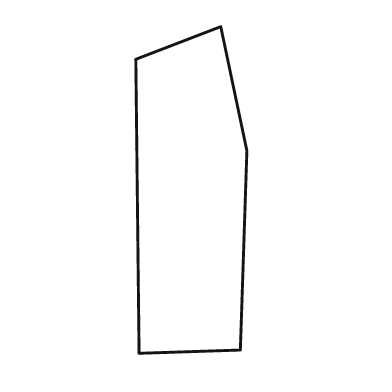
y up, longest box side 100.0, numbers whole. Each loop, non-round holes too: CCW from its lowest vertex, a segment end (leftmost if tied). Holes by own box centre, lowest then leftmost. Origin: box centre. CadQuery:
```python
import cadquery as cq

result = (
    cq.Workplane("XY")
    .moveTo(-16.0, -50.0)
    .lineTo(15.0, -49.0)
    .lineTo(17.0, 12.0)
    .lineTo(9.0, 50.0)
    .lineTo(-17.0, 40.0)
    .close()
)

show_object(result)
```